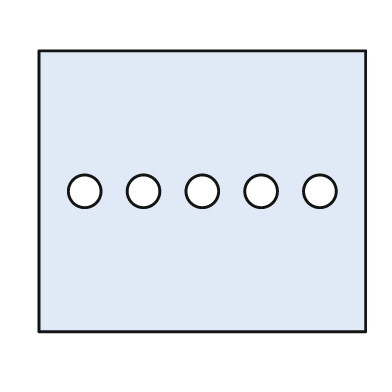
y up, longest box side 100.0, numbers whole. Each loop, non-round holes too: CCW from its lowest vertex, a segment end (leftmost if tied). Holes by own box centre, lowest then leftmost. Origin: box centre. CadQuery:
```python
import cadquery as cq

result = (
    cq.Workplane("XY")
    .moveTo(-50.0, -43.0)
    .lineTo(50.0, -43.0)
    .lineTo(50.0, 43.0)
    .lineTo(-50.0, 43.0)
    .close()
    .moveTo(-36.0, 0.0)
    .circle(5.0)
    .moveTo(-18.0, 0.0)
    .circle(5.0)
    .moveTo(0.0, 0.0)
    .circle(5.0)
    .moveTo(18.0, 0.0)
    .circle(5.0)
    .moveTo(36.0, 0.0)
    .circle(5.0)
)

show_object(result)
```